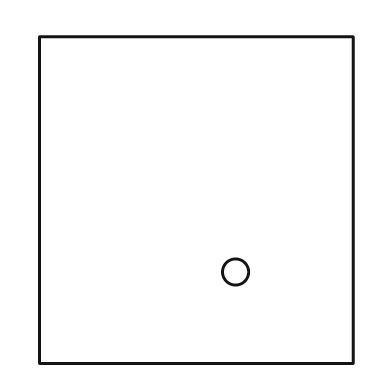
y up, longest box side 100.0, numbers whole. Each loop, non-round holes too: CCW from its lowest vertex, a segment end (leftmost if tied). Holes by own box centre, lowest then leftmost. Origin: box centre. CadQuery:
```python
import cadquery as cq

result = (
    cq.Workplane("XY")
    .moveTo(-48.0, -50.0)
    .lineTo(48.0, -50.0)
    .lineTo(48.0, 50.0)
    .lineTo(-48.0, 50.0)
    .close()
    .moveTo(12.0, -22.0)
    .circle(4.0)
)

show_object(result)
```